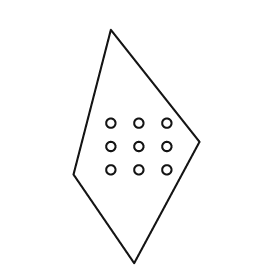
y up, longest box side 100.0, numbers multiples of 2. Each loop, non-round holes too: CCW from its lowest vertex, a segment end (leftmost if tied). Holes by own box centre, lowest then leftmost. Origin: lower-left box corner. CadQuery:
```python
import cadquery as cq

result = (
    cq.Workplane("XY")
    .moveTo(26.0, 0.0)
    .lineTo(54.0, 52.0)
    .lineTo(16.0, 100.0)
    .lineTo(0.0, 38.0)
    .close()
    .moveTo(16.0, 40.0)
    .circle(2.0)
    .moveTo(28.0, 40.0)
    .circle(2.0)
    .moveTo(40.0, 40.0)
    .circle(2.0)
    .moveTo(16.0, 50.0)
    .circle(2.0)
    .moveTo(28.0, 50.0)
    .circle(2.0)
    .moveTo(40.0, 50.0)
    .circle(2.0)
    .moveTo(16.0, 60.0)
    .circle(2.0)
    .moveTo(28.0, 60.0)
    .circle(2.0)
    .moveTo(40.0, 60.0)
    .circle(2.0)
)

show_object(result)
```